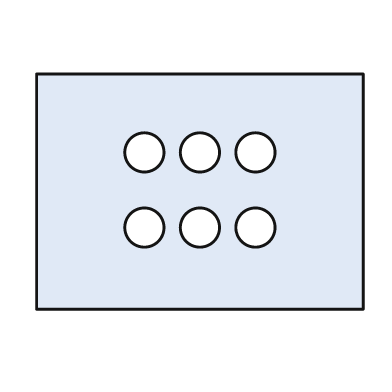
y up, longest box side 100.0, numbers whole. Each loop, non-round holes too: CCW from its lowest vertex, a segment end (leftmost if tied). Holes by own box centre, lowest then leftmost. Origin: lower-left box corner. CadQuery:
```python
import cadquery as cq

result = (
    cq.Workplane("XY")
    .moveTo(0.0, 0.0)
    .lineTo(100.0, 0.0)
    .lineTo(100.0, 72.0)
    .lineTo(0.0, 72.0)
    .close()
    .moveTo(33.0, 25.0)
    .circle(6.0)
    .moveTo(50.0, 25.0)
    .circle(6.0)
    .moveTo(67.0, 25.0)
    .circle(6.0)
    .moveTo(33.0, 48.0)
    .circle(6.0)
    .moveTo(50.0, 48.0)
    .circle(6.0)
    .moveTo(67.0, 48.0)
    .circle(6.0)
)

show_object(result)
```